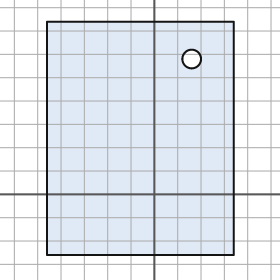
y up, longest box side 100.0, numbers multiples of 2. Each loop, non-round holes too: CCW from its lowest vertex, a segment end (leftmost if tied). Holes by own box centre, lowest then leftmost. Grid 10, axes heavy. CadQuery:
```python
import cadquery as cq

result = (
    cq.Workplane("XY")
    .moveTo(-46.0, -26.0)
    .lineTo(34.0, -26.0)
    .lineTo(34.0, 74.0)
    .lineTo(-46.0, 74.0)
    .close()
    .moveTo(16.0, 58.0)
    .circle(4.0)
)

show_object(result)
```